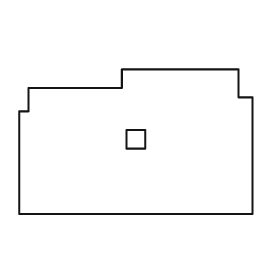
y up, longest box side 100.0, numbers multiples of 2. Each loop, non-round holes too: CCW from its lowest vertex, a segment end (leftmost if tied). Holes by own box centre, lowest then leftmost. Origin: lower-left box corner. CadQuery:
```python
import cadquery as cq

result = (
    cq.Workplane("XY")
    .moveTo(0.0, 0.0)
    .lineTo(100.0, 0.0)
    .lineTo(100.0, 50.0)
    .lineTo(94.0, 50.0)
    .lineTo(94.0, 62.0)
    .lineTo(44.0, 62.0)
    .lineTo(44.0, 54.0)
    .lineTo(4.0, 54.0)
    .lineTo(4.0, 44.0)
    .lineTo(0.0, 44.0)
    .close()
    .moveTo(46.0, 28.0)
    .lineTo(54.0, 28.0)
    .lineTo(54.0, 36.0)
    .lineTo(46.0, 36.0)
    .close()
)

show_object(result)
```